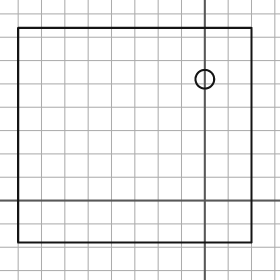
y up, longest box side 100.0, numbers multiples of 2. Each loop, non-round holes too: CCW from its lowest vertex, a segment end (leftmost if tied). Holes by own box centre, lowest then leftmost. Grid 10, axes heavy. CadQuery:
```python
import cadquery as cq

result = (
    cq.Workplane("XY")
    .moveTo(-80.0, -18.0)
    .lineTo(20.0, -18.0)
    .lineTo(20.0, 74.0)
    .lineTo(-80.0, 74.0)
    .close()
    .moveTo(0.0, 52.0)
    .circle(4.0)
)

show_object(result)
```